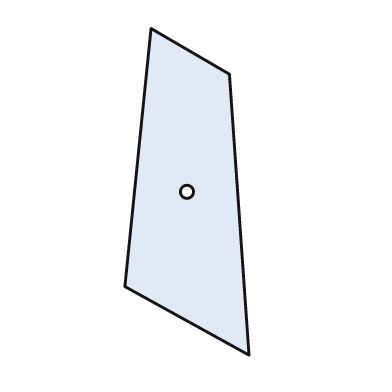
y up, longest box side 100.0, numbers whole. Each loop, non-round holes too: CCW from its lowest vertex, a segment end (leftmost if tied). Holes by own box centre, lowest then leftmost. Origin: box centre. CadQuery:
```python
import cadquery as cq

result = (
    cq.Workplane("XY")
    .moveTo(19.0, -50.0)
    .lineTo(13.0, 36.0)
    .lineTo(-11.0, 50.0)
    .lineTo(-19.0, -29.0)
    .close()
    .moveTo(0.0, 0.0)
    .circle(2.0)
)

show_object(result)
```